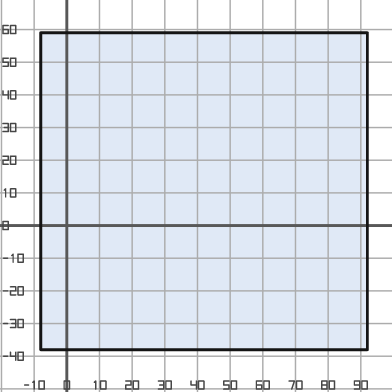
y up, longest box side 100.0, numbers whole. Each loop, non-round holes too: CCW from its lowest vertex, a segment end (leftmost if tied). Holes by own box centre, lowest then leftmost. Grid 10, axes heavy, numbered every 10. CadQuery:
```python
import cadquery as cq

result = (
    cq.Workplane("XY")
    .moveTo(-8.0, -38.0)
    .lineTo(92.0, -38.0)
    .lineTo(92.0, 59.0)
    .lineTo(-8.0, 59.0)
    .close()
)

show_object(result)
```